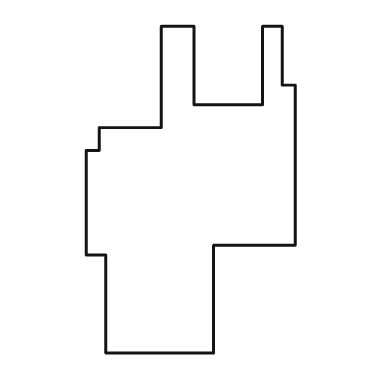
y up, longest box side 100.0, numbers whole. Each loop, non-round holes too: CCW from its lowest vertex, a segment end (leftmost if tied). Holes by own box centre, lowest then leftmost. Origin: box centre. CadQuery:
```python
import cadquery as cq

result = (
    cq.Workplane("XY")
    .moveTo(-26.0, -50.0)
    .lineTo(7.0, -50.0)
    .lineTo(7.0, -17.0)
    .lineTo(32.0, -17.0)
    .lineTo(32.0, 32.0)
    .lineTo(28.0, 32.0)
    .lineTo(28.0, 50.0)
    .lineTo(22.0, 50.0)
    .lineTo(22.0, 26.0)
    .lineTo(1.0, 26.0)
    .lineTo(1.0, 50.0)
    .lineTo(-9.0, 50.0)
    .lineTo(-9.0, 19.0)
    .lineTo(-28.0, 19.0)
    .lineTo(-28.0, 12.0)
    .lineTo(-32.0, 12.0)
    .lineTo(-32.0, -20.0)
    .lineTo(-26.0, -20.0)
    .close()
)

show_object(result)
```